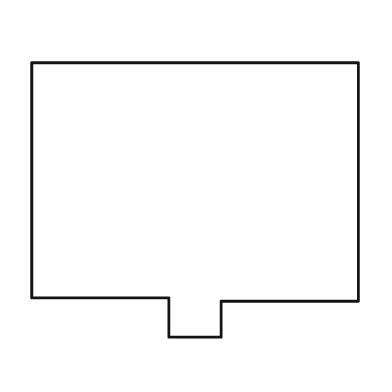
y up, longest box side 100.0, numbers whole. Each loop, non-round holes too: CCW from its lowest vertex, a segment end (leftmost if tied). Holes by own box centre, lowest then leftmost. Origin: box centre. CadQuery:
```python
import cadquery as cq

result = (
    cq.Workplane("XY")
    .moveTo(-8.0, -42.0)
    .lineTo(8.0, -42.0)
    .lineTo(8.0, -31.0)
    .lineTo(50.0, -31.0)
    .lineTo(50.0, 42.0)
    .lineTo(-50.0, 42.0)
    .lineTo(-50.0, -30.0)
    .lineTo(-8.0, -30.0)
    .close()
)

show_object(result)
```